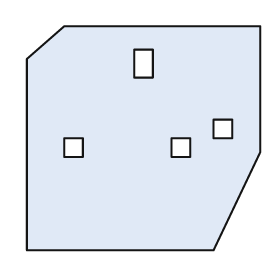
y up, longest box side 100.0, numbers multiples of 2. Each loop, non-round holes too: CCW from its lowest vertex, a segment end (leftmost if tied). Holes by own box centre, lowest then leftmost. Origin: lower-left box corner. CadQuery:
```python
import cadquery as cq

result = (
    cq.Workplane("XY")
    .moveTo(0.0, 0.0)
    .lineTo(80.0, 0.0)
    .lineTo(100.0, 42.0)
    .lineTo(100.0, 96.0)
    .lineTo(16.0, 96.0)
    .lineTo(0.0, 82.0)
    .close()
    .moveTo(16.0, 40.0)
    .lineTo(24.0, 40.0)
    .lineTo(24.0, 48.0)
    .lineTo(16.0, 48.0)
    .close()
    .moveTo(62.0, 40.0)
    .lineTo(70.0, 40.0)
    .lineTo(70.0, 48.0)
    .lineTo(62.0, 48.0)
    .close()
    .moveTo(80.0, 48.0)
    .lineTo(88.0, 48.0)
    .lineTo(88.0, 56.0)
    .lineTo(80.0, 56.0)
    .close()
    .moveTo(46.0, 74.0)
    .lineTo(54.0, 74.0)
    .lineTo(54.0, 86.0)
    .lineTo(46.0, 86.0)
    .close()
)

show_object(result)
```